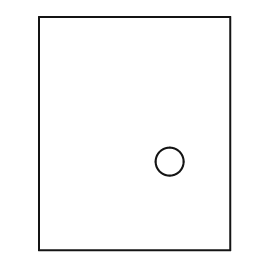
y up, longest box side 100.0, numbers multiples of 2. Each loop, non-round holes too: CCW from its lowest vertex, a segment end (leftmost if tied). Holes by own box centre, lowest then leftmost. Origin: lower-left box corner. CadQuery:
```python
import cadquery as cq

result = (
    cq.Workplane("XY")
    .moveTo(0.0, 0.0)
    .lineTo(82.0, 0.0)
    .lineTo(82.0, 100.0)
    .lineTo(0.0, 100.0)
    .close()
    .moveTo(56.0, 38.0)
    .circle(6.0)
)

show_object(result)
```